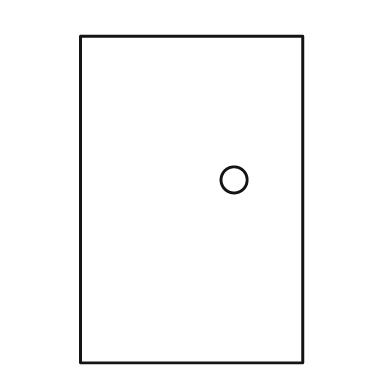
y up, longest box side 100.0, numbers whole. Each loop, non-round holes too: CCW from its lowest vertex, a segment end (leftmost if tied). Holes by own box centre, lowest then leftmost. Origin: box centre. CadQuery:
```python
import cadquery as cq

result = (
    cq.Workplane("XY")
    .moveTo(-34.0, -50.0)
    .lineTo(34.0, -50.0)
    .lineTo(34.0, 50.0)
    .lineTo(-34.0, 50.0)
    .close()
    .moveTo(13.0, 6.0)
    .circle(4.0)
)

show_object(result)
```